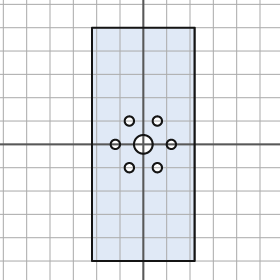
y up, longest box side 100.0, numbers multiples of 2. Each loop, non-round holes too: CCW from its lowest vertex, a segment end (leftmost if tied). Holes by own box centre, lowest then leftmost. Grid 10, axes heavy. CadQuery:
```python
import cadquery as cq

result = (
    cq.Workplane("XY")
    .moveTo(-22.0, -50.0)
    .lineTo(22.0, -50.0)
    .lineTo(22.0, 50.0)
    .lineTo(-22.0, 50.0)
    .close()
    .moveTo(-6.0, -10.0)
    .circle(2.0)
    .moveTo(6.0, -10.0)
    .circle(2.0)
    .moveTo(-12.0, 0.0)
    .circle(2.0)
    .moveTo(0.0, 0.0)
    .circle(4.0)
    .moveTo(12.0, 0.0)
    .circle(2.0)
    .moveTo(-6.0, 10.0)
    .circle(2.0)
    .moveTo(6.0, 10.0)
    .circle(2.0)
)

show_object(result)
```